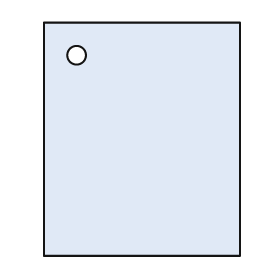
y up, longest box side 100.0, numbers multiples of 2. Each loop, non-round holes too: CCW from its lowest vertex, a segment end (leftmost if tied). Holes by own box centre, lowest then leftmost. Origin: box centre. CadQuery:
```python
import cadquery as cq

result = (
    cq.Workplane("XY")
    .moveTo(-42.0, -50.0)
    .lineTo(42.0, -50.0)
    .lineTo(42.0, 50.0)
    .lineTo(-42.0, 50.0)
    .close()
    .moveTo(-28.0, 36.0)
    .circle(4.0)
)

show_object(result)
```